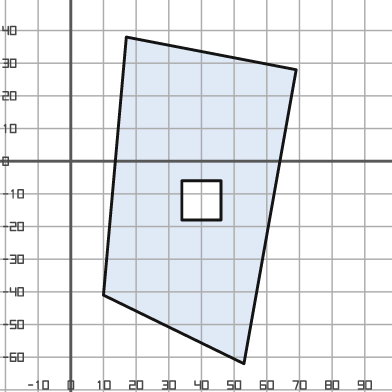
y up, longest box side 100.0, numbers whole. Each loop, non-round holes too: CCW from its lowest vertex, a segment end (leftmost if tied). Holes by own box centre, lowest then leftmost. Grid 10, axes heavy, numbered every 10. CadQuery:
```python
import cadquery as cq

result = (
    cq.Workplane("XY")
    .moveTo(53.0, -62.0)
    .lineTo(69.0, 28.0)
    .lineTo(17.0, 38.0)
    .lineTo(10.0, -41.0)
    .close()
    .moveTo(34.0, -18.0)
    .lineTo(46.0, -18.0)
    .lineTo(46.0, -6.0)
    .lineTo(34.0, -6.0)
    .close()
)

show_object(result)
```